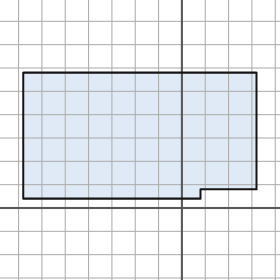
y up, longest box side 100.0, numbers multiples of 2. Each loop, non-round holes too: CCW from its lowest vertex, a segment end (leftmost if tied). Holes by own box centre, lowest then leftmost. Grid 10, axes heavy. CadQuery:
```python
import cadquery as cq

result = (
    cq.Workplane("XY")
    .moveTo(-68.0, 4.0)
    .lineTo(8.0, 4.0)
    .lineTo(8.0, 8.0)
    .lineTo(32.0, 8.0)
    .lineTo(32.0, 58.0)
    .lineTo(-68.0, 58.0)
    .close()
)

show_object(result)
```